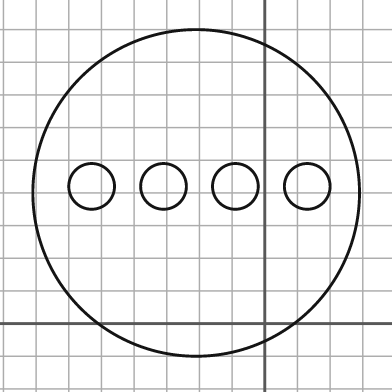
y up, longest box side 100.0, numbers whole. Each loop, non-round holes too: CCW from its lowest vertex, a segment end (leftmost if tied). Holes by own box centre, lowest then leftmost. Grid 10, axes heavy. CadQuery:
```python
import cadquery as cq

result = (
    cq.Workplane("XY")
    .moveTo(-21.0, 40.0)
    .circle(50.0)
    .moveTo(-53.0, 42.0)
    .circle(7.0)
    .moveTo(-31.0, 42.0)
    .circle(7.0)
    .moveTo(-9.0, 42.0)
    .circle(7.0)
    .moveTo(13.0, 42.0)
    .circle(7.0)
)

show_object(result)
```